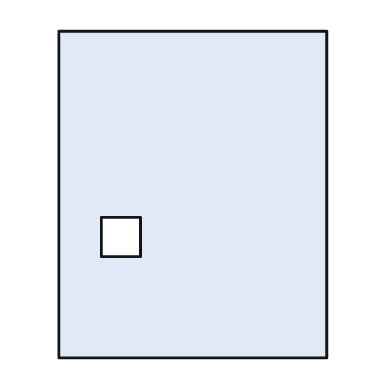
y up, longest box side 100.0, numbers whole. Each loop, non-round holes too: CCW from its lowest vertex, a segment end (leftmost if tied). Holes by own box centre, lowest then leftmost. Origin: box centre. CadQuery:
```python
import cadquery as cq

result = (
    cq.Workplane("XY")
    .moveTo(-41.0, -50.0)
    .lineTo(41.0, -50.0)
    .lineTo(41.0, 50.0)
    .lineTo(-41.0, 50.0)
    .close()
    .moveTo(-28.0, -19.0)
    .lineTo(-16.0, -19.0)
    .lineTo(-16.0, -7.0)
    .lineTo(-28.0, -7.0)
    .close()
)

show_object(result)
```